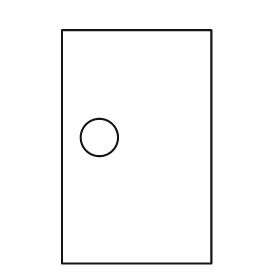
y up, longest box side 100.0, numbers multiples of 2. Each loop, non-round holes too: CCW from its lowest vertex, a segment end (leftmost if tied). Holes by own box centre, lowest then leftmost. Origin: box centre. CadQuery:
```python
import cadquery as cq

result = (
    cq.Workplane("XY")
    .moveTo(-32.0, -50.0)
    .lineTo(32.0, -50.0)
    .lineTo(32.0, 50.0)
    .lineTo(-32.0, 50.0)
    .close()
    .moveTo(-16.0, 4.0)
    .circle(8.0)
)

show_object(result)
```